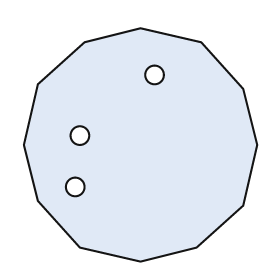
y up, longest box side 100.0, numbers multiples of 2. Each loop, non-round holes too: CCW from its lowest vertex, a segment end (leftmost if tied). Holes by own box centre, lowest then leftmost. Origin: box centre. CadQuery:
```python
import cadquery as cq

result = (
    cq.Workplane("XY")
    .moveTo(0.0, -50.0)
    .lineTo(24.0, -44.0)
    .lineTo(44.0, -26.0)
    .lineTo(50.0, 0.0)
    .lineTo(44.0, 24.0)
    .lineTo(26.0, 44.0)
    .lineTo(0.0, 50.0)
    .lineTo(-24.0, 44.0)
    .lineTo(-44.0, 26.0)
    .lineTo(-50.0, 0.0)
    .lineTo(-44.0, -24.0)
    .lineTo(-26.0, -44.0)
    .close()
    .moveTo(-28.0, -18.0)
    .circle(4.0)
    .moveTo(-26.0, 4.0)
    .circle(4.0)
    .moveTo(6.0, 30.0)
    .circle(4.0)
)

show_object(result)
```